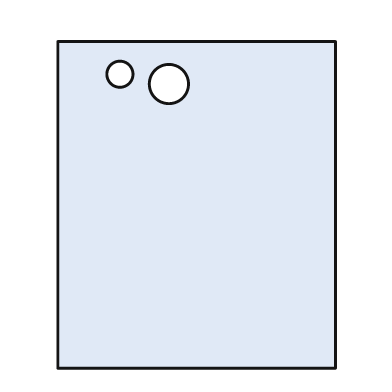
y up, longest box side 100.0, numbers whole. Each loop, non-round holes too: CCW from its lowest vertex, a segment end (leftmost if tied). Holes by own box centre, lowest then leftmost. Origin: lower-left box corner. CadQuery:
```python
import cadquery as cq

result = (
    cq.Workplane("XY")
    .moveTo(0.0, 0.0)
    .lineTo(85.0, 0.0)
    .lineTo(85.0, 100.0)
    .lineTo(0.0, 100.0)
    .close()
    .moveTo(34.0, 87.0)
    .circle(6.0)
    .moveTo(19.0, 90.0)
    .circle(4.0)
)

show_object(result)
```